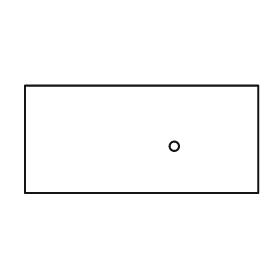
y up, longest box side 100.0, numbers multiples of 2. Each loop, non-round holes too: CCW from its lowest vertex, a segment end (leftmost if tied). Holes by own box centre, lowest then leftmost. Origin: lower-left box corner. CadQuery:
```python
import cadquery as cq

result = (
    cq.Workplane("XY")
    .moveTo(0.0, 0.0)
    .lineTo(100.0, 0.0)
    .lineTo(100.0, 46.0)
    .lineTo(0.0, 46.0)
    .close()
    .moveTo(64.0, 20.0)
    .circle(2.0)
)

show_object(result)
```